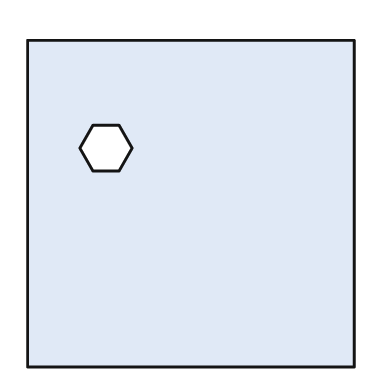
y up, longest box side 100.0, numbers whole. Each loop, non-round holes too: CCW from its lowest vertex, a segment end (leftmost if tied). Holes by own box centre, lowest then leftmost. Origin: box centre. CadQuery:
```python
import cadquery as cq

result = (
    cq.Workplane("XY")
    .moveTo(-50.0, -50.0)
    .lineTo(50.0, -50.0)
    .lineTo(50.0, 50.0)
    .lineTo(-50.0, 50.0)
    .close()
    .moveTo(-30.0, 10.0)
    .lineTo(-22.0, 10.0)
    .lineTo(-18.0, 17.0)
    .lineTo(-22.0, 24.0)
    .lineTo(-30.0, 24.0)
    .lineTo(-34.0, 17.0)
    .close()
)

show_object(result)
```